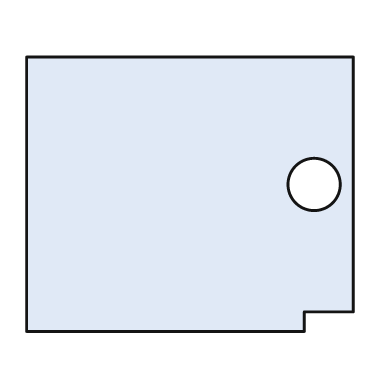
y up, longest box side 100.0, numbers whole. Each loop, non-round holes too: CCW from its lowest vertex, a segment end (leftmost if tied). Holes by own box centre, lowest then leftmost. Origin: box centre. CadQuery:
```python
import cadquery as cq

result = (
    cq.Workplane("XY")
    .moveTo(-50.0, -42.0)
    .lineTo(35.0, -42.0)
    .lineTo(35.0, -36.0)
    .lineTo(50.0, -36.0)
    .lineTo(50.0, 42.0)
    .lineTo(-50.0, 42.0)
    .close()
    .moveTo(38.0, 3.0)
    .circle(8.0)
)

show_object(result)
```